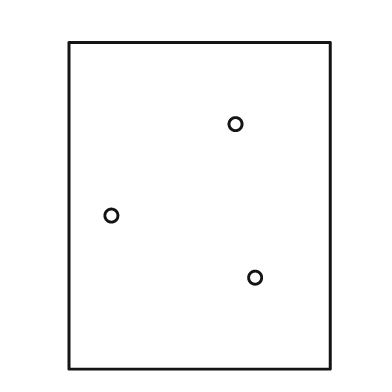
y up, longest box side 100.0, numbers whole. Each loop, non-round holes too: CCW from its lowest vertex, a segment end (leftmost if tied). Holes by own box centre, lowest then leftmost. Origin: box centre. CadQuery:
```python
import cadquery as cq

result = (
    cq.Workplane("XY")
    .moveTo(-40.0, -50.0)
    .lineTo(40.0, -50.0)
    .lineTo(40.0, 50.0)
    .lineTo(-40.0, 50.0)
    .close()
    .moveTo(17.0, -22.0)
    .circle(2.0)
    .moveTo(-27.0, -3.0)
    .circle(2.0)
    .moveTo(11.0, 25.0)
    .circle(2.0)
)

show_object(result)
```